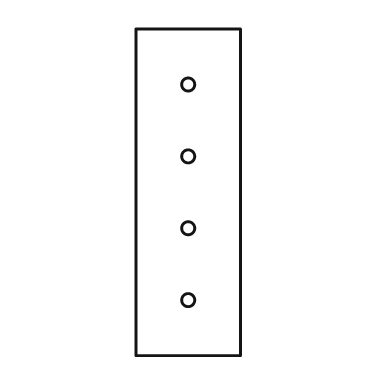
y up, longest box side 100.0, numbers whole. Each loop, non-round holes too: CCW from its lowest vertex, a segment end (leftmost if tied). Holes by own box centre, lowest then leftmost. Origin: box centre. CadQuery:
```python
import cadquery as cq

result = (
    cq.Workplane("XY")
    .moveTo(-16.0, -50.0)
    .lineTo(16.0, -50.0)
    .lineTo(16.0, 50.0)
    .lineTo(-16.0, 50.0)
    .close()
    .moveTo(0.0, -33.0)
    .circle(2.0)
    .moveTo(0.0, -11.0)
    .circle(2.0)
    .moveTo(0.0, 11.0)
    .circle(2.0)
    .moveTo(0.0, 33.0)
    .circle(2.0)
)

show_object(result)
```